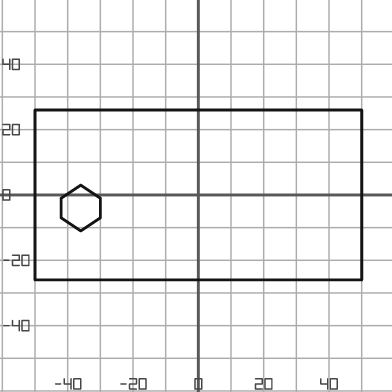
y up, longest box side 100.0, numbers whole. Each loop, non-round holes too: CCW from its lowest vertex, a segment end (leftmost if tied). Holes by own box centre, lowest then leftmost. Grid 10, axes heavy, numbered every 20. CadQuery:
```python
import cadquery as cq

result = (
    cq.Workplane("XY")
    .moveTo(-50.0, -26.0)
    .lineTo(50.0, -26.0)
    .lineTo(50.0, 26.0)
    .lineTo(-50.0, 26.0)
    .close()
    .moveTo(-36.0, -11.0)
    .lineTo(-30.0, -7.0)
    .lineTo(-30.0, -1.0)
    .lineTo(-36.0, 3.0)
    .lineTo(-42.0, -1.0)
    .lineTo(-42.0, -7.0)
    .close()
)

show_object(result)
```